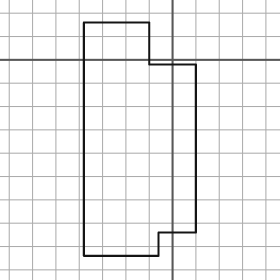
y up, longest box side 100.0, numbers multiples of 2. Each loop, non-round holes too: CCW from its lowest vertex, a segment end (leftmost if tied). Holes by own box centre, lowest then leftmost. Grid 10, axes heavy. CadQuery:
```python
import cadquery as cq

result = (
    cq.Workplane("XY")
    .moveTo(-38.0, -84.0)
    .lineTo(-6.0, -84.0)
    .lineTo(-6.0, -74.0)
    .lineTo(10.0, -74.0)
    .lineTo(10.0, -2.0)
    .lineTo(-10.0, -2.0)
    .lineTo(-10.0, 16.0)
    .lineTo(-38.0, 16.0)
    .close()
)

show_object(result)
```